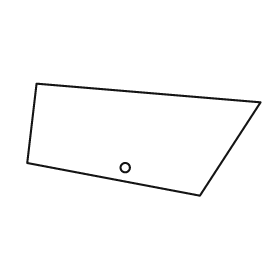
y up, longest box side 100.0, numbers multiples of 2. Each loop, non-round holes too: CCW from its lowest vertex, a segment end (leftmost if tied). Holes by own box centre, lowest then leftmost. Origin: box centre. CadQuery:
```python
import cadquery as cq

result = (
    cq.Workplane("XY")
    .moveTo(24.0, -24.0)
    .lineTo(50.0, 16.0)
    .lineTo(-46.0, 24.0)
    .lineTo(-50.0, -10.0)
    .close()
    .moveTo(-8.0, -12.0)
    .circle(2.0)
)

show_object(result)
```